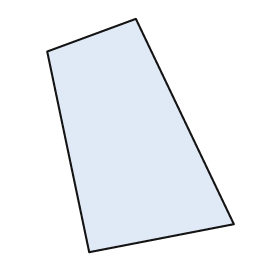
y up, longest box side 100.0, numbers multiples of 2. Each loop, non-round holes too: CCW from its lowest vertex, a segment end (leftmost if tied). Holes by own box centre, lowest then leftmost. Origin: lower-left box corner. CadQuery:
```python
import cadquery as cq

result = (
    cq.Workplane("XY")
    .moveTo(18.0, 0.0)
    .lineTo(80.0, 12.0)
    .lineTo(38.0, 100.0)
    .lineTo(0.0, 86.0)
    .close()
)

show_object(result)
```